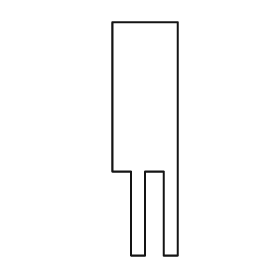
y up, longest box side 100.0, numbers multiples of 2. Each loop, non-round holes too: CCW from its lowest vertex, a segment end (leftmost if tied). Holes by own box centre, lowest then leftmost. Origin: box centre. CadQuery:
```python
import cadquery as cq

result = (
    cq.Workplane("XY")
    .moveTo(-6.0, -50.0)
    .lineTo(0.0, -50.0)
    .lineTo(0.0, -14.0)
    .lineTo(8.0, -14.0)
    .lineTo(8.0, -50.0)
    .lineTo(14.0, -50.0)
    .lineTo(14.0, 50.0)
    .lineTo(-14.0, 50.0)
    .lineTo(-14.0, -14.0)
    .lineTo(-6.0, -14.0)
    .close()
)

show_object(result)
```